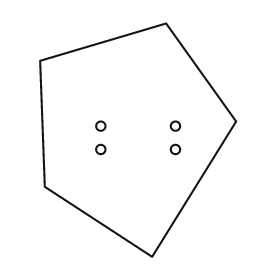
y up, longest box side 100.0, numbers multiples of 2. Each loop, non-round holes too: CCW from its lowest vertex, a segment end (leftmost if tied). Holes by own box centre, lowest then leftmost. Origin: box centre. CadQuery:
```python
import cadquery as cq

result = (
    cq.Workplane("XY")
    .moveTo(6.0, -50.0)
    .lineTo(42.0, 8.0)
    .lineTo(12.0, 50.0)
    .lineTo(-42.0, 34.0)
    .lineTo(-40.0, -20.0)
    .close()
    .moveTo(-16.0, -4.0)
    .circle(2.0)
    .moveTo(16.0, -4.0)
    .circle(2.0)
    .moveTo(-16.0, 6.0)
    .circle(2.0)
    .moveTo(16.0, 6.0)
    .circle(2.0)
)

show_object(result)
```